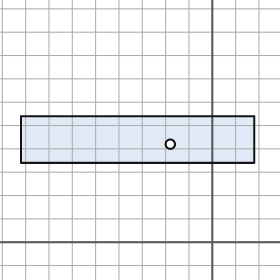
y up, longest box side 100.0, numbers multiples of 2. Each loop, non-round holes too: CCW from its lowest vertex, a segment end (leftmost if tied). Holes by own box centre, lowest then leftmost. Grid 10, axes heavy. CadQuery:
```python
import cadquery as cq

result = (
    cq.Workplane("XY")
    .moveTo(-82.0, 34.0)
    .lineTo(18.0, 34.0)
    .lineTo(18.0, 54.0)
    .lineTo(-82.0, 54.0)
    .close()
    .moveTo(-18.0, 42.0)
    .circle(2.0)
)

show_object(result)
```